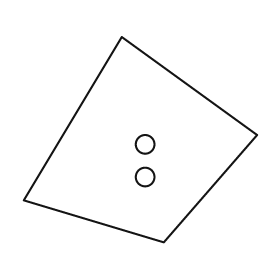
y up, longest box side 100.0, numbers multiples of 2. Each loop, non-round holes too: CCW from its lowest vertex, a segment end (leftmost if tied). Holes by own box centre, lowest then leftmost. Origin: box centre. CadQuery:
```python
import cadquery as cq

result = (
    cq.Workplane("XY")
    .moveTo(10.0, -44.0)
    .lineTo(50.0, 2.0)
    .lineTo(-8.0, 44.0)
    .lineTo(-50.0, -26.0)
    .close()
    .moveTo(2.0, -16.0)
    .circle(4.0)
    .moveTo(2.0, -2.0)
    .circle(4.0)
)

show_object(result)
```